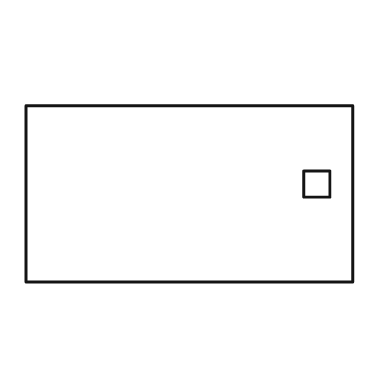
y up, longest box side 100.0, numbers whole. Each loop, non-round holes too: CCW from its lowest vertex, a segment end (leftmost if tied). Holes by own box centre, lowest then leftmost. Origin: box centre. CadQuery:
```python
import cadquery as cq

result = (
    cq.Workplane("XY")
    .moveTo(-50.0, -27.0)
    .lineTo(50.0, -27.0)
    .lineTo(50.0, 27.0)
    .lineTo(-50.0, 27.0)
    .close()
    .moveTo(35.0, -1.0)
    .lineTo(43.0, -1.0)
    .lineTo(43.0, 7.0)
    .lineTo(35.0, 7.0)
    .close()
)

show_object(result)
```